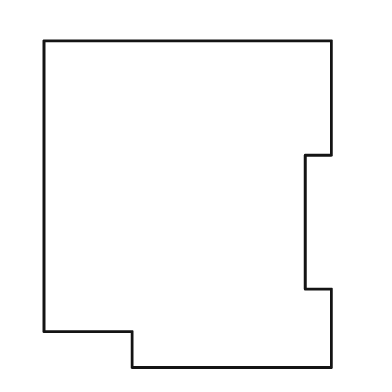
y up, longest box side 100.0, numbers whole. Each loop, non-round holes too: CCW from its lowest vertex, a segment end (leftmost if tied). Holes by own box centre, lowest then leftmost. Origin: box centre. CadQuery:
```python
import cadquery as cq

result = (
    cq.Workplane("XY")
    .moveTo(-17.0, -50.0)
    .lineTo(44.0, -50.0)
    .lineTo(44.0, -26.0)
    .lineTo(36.0, -26.0)
    .lineTo(36.0, 15.0)
    .lineTo(44.0, 15.0)
    .lineTo(44.0, 50.0)
    .lineTo(-44.0, 50.0)
    .lineTo(-44.0, -39.0)
    .lineTo(-17.0, -39.0)
    .close()
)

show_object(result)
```